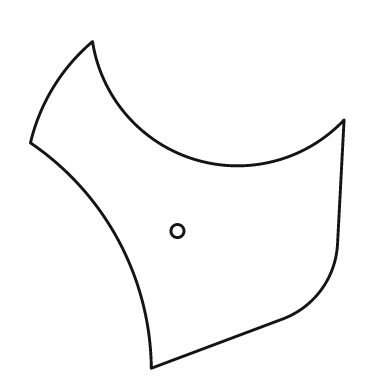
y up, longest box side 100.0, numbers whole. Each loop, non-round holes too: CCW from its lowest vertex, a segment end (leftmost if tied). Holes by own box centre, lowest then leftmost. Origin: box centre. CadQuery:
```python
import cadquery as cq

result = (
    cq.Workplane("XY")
    .moveTo(-11.0, -50.0)
    .lineTo(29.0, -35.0)
    .threePointArc((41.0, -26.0), (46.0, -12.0))
    .lineTo(48.0, 26.0)
    .threePointArc((2.0, 14.0), (-29.0, 50.0))
    .threePointArc((-41.0, 36.0), (-48.0, 19.0))
    .threePointArc((-21.0, -11.0), (-11.0, -50.0))
    .close()
    .moveTo(-3.0, -8.0)
    .circle(2.0)
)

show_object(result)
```